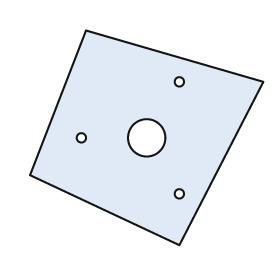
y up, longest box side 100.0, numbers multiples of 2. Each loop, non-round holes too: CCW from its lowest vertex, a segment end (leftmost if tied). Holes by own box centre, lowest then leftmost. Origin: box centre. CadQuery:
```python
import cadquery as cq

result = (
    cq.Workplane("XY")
    .moveTo(14.0, -46.0)
    .lineTo(50.0, 24.0)
    .lineTo(-26.0, 46.0)
    .lineTo(-50.0, -16.0)
    .close()
    .moveTo(14.0, -24.0)
    .circle(2.0)
    .moveTo(-28.0, 0.0)
    .circle(2.0)
    .moveTo(0.0, 0.0)
    .circle(8.0)
    .moveTo(14.0, 24.0)
    .circle(2.0)
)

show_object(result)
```